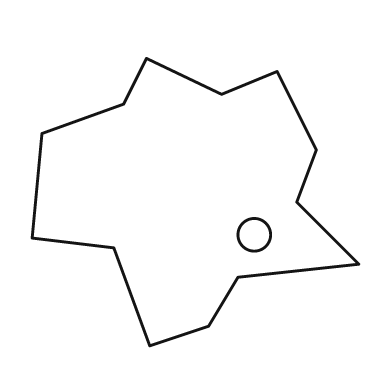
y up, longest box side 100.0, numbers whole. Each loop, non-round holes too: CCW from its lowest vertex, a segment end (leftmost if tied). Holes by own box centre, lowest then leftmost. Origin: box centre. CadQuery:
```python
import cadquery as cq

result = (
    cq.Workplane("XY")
    .moveTo(-14.0, -44.0)
    .lineTo(4.0, -38.0)
    .lineTo(13.0, -23.0)
    .lineTo(50.0, -19.0)
    .lineTo(31.0, 0.0)
    .lineTo(37.0, 16.0)
    .lineTo(25.0, 40.0)
    .lineTo(8.0, 33.0)
    .lineTo(-15.0, 44.0)
    .lineTo(-22.0, 30.0)
    .lineTo(-47.0, 21.0)
    .lineTo(-50.0, -11.0)
    .lineTo(-25.0, -14.0)
    .close()
    .moveTo(18.0, -10.0)
    .circle(5.0)
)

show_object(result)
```